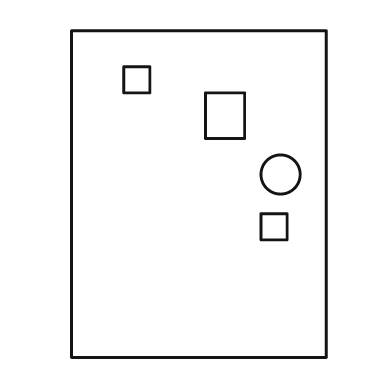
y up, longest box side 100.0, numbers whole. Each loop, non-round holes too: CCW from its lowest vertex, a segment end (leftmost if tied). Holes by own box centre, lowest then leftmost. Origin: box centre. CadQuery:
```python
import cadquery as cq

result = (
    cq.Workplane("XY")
    .moveTo(-39.0, -50.0)
    .lineTo(39.0, -50.0)
    .lineTo(39.0, 50.0)
    .lineTo(-39.0, 50.0)
    .close()
    .moveTo(19.0, -14.0)
    .lineTo(27.0, -14.0)
    .lineTo(27.0, -6.0)
    .lineTo(19.0, -6.0)
    .close()
    .moveTo(25.0, 6.0)
    .circle(6.0)
    .moveTo(2.0, 17.0)
    .lineTo(14.0, 17.0)
    .lineTo(14.0, 31.0)
    .lineTo(2.0, 31.0)
    .close()
    .moveTo(-23.0, 31.0)
    .lineTo(-15.0, 31.0)
    .lineTo(-15.0, 39.0)
    .lineTo(-23.0, 39.0)
    .close()
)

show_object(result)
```